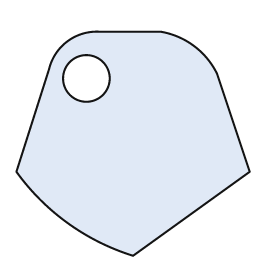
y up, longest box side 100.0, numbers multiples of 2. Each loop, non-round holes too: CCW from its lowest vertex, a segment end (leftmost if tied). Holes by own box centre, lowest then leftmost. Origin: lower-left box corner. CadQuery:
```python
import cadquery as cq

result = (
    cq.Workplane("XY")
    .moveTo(50.0, 0.0)
    .lineTo(100.0, 36.0)
    .lineTo(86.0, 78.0)
    .threePointArc((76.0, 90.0), (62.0, 96.0))
    .lineTo(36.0, 96.0)
    .threePointArc((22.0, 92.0), (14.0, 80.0))
    .lineTo(0.0, 36.0)
    .threePointArc((22.0, 14.0), (50.0, 0.0))
    .close()
    .moveTo(30.0, 76.0)
    .circle(10.0)
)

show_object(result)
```